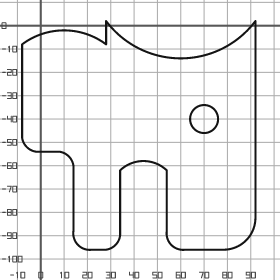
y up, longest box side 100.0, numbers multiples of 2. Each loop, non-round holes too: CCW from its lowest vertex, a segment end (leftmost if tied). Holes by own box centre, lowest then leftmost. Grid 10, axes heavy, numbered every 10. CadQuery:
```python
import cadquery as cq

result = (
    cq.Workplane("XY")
    .moveTo(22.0, -96.0)
    .lineTo(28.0, -96.0)
    .threePointArc((32.0, -94.0), (34.0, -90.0))
    .lineTo(34.0, -62.0)
    .threePointArc((44.0, -58.0), (54.0, -62.0))
    .lineTo(54.0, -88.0)
    .threePointArc((56.0, -94.0), (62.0, -96.0))
    .lineTo(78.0, -96.0)
    .threePointArc((88.0, -92.0), (92.0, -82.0))
    .lineTo(92.0, 2.0)
    .threePointArc((60.0, -14.0), (28.0, 2.0))
    .lineTo(28.0, -8.0)
    .threePointArc((10.0, -2.0), (-8.0, -8.0))
    .lineTo(-8.0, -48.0)
    .threePointArc((-6.0, -52.0), (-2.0, -54.0))
    .lineTo(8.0, -54.0)
    .threePointArc((12.0, -56.0), (14.0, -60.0))
    .lineTo(14.0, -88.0)
    .threePointArc((16.0, -94.0), (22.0, -96.0))
    .close()
    .moveTo(70.0, -40.0)
    .circle(6.0)
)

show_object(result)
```